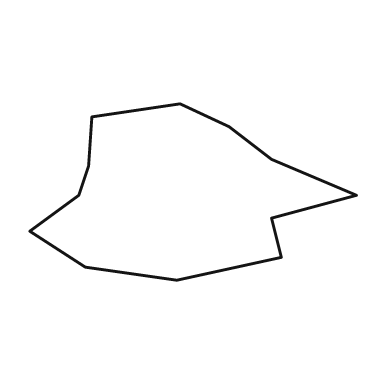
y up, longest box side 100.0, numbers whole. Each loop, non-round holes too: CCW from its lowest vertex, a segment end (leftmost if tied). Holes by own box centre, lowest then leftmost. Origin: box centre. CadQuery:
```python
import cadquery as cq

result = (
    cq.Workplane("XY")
    .moveTo(-5.0, -27.0)
    .lineTo(27.0, -20.0)
    .lineTo(24.0, -8.0)
    .lineTo(50.0, -1.0)
    .lineTo(24.0, 10.0)
    .lineTo(11.0, 20.0)
    .lineTo(-4.0, 27.0)
    .lineTo(-31.0, 23.0)
    .lineTo(-32.0, 8.0)
    .lineTo(-35.0, -1.0)
    .lineTo(-50.0, -12.0)
    .lineTo(-33.0, -23.0)
    .close()
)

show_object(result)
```